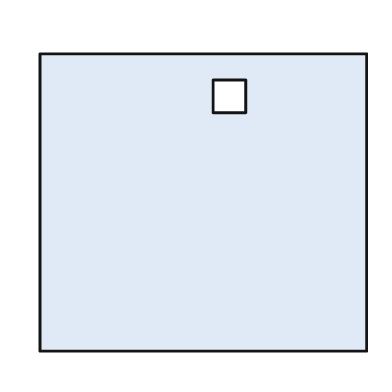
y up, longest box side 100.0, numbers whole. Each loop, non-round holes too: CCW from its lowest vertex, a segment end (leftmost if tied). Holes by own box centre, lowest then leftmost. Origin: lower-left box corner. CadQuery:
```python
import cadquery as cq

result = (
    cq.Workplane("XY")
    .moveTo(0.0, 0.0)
    .lineTo(100.0, 0.0)
    .lineTo(100.0, 91.0)
    .lineTo(0.0, 91.0)
    .close()
    .moveTo(53.0, 73.0)
    .lineTo(63.0, 73.0)
    .lineTo(63.0, 83.0)
    .lineTo(53.0, 83.0)
    .close()
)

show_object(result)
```